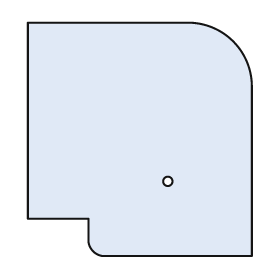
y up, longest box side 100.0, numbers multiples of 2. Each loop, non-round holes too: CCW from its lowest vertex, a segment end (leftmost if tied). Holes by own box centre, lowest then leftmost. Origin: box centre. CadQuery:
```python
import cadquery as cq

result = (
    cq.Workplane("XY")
    .moveTo(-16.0, -50.0)
    .lineTo(48.0, -50.0)
    .lineTo(48.0, 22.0)
    .threePointArc((40.0, 42.0), (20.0, 50.0))
    .lineTo(-48.0, 50.0)
    .lineTo(-48.0, -34.0)
    .lineTo(-22.0, -34.0)
    .lineTo(-22.0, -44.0)
    .threePointArc((-20.0, -48.0), (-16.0, -50.0))
    .close()
    .moveTo(12.0, -18.0)
    .circle(2.0)
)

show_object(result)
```